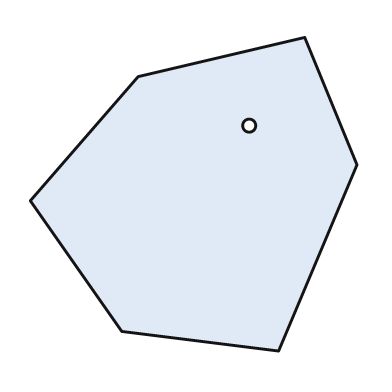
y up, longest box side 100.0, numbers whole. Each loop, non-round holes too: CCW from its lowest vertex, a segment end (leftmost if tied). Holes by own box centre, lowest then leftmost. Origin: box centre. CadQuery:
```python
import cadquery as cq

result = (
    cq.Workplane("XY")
    .moveTo(26.0, -48.0)
    .lineTo(50.0, 9.0)
    .lineTo(34.0, 48.0)
    .lineTo(-17.0, 36.0)
    .lineTo(-50.0, -2.0)
    .lineTo(-22.0, -42.0)
    .close()
    .moveTo(17.0, 21.0)
    .circle(2.0)
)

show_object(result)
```